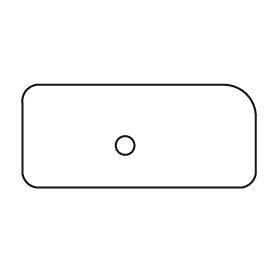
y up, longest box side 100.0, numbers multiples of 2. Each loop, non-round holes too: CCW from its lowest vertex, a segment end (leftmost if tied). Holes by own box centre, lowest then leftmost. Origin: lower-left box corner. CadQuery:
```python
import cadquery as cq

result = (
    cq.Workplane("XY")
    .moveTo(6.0, 0.0)
    .lineTo(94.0, 0.0)
    .threePointArc((98.0, 2.0), (100.0, 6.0))
    .lineTo(100.0, 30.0)
    .threePointArc((96.0, 40.0), (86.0, 44.0))
    .lineTo(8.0, 44.0)
    .threePointArc((2.0, 42.0), (0.0, 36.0))
    .lineTo(0.0, 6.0)
    .threePointArc((2.0, 2.0), (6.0, 0.0))
    .close()
    .moveTo(44.0, 18.0)
    .circle(4.0)
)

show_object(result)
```